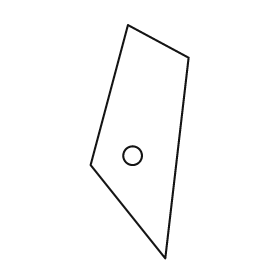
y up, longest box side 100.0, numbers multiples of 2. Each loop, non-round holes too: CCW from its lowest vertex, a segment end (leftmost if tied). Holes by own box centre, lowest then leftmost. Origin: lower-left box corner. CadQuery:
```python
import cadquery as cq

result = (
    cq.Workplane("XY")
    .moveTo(32.0, 0.0)
    .lineTo(42.0, 86.0)
    .lineTo(16.0, 100.0)
    .lineTo(0.0, 40.0)
    .close()
    .moveTo(18.0, 44.0)
    .circle(4.0)
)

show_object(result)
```